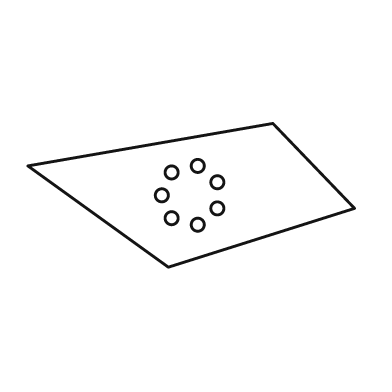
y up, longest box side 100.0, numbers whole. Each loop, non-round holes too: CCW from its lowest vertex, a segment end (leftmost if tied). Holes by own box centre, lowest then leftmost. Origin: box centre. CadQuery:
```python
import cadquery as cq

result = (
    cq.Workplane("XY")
    .moveTo(-7.0, -22.0)
    .lineTo(50.0, -4.0)
    .lineTo(25.0, 22.0)
    .lineTo(-50.0, 9.0)
    .close()
    .moveTo(2.0, -9.0)
    .circle(2.0)
    .moveTo(-6.0, -7.0)
    .circle(2.0)
    .moveTo(8.0, -4.0)
    .circle(2.0)
    .moveTo(-9.0, 0.0)
    .circle(2.0)
    .moveTo(8.0, 4.0)
    .circle(2.0)
    .moveTo(-6.0, 7.0)
    .circle(2.0)
    .moveTo(2.0, 9.0)
    .circle(2.0)
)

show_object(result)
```